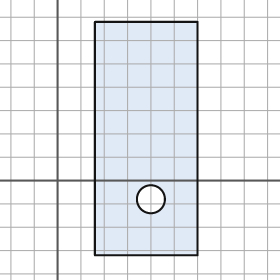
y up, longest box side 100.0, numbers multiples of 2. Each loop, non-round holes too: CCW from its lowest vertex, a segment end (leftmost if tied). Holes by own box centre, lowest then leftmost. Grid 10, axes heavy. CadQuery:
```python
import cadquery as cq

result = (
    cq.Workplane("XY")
    .moveTo(16.0, -32.0)
    .lineTo(60.0, -32.0)
    .lineTo(60.0, 68.0)
    .lineTo(16.0, 68.0)
    .close()
    .moveTo(40.0, -8.0)
    .circle(6.0)
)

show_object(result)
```